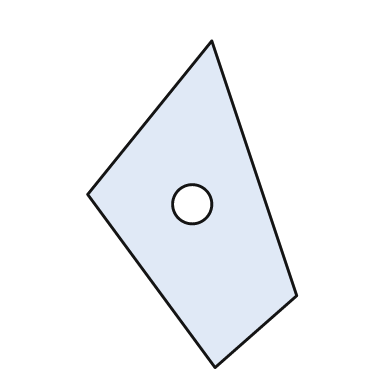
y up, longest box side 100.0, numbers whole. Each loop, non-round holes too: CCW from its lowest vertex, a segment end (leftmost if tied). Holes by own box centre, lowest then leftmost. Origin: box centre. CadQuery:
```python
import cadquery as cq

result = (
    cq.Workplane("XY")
    .moveTo(7.0, -50.0)
    .lineTo(32.0, -28.0)
    .lineTo(6.0, 50.0)
    .lineTo(-32.0, 3.0)
    .close()
    .moveTo(0.0, 0.0)
    .circle(6.0)
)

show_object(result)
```